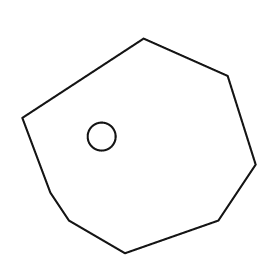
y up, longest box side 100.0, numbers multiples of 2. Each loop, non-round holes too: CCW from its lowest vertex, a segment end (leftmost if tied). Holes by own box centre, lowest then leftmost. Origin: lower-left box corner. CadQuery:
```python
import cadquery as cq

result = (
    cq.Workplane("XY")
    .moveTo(44.0, 0.0)
    .lineTo(84.0, 14.0)
    .lineTo(100.0, 38.0)
    .lineTo(88.0, 76.0)
    .lineTo(52.0, 92.0)
    .lineTo(0.0, 58.0)
    .lineTo(12.0, 26.0)
    .lineTo(20.0, 14.0)
    .close()
    .moveTo(34.0, 50.0)
    .circle(6.0)
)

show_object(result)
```